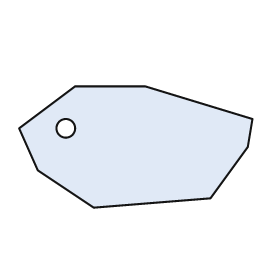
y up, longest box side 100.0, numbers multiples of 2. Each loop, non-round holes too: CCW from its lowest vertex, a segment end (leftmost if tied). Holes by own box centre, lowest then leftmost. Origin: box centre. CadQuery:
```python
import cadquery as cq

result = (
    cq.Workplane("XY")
    .moveTo(-18.0, -26.0)
    .lineTo(32.0, -22.0)
    .lineTo(48.0, 0.0)
    .lineTo(50.0, 12.0)
    .lineTo(4.0, 26.0)
    .lineTo(-26.0, 26.0)
    .lineTo(-50.0, 8.0)
    .lineTo(-42.0, -10.0)
    .close()
    .moveTo(-30.0, 8.0)
    .circle(4.0)
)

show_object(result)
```